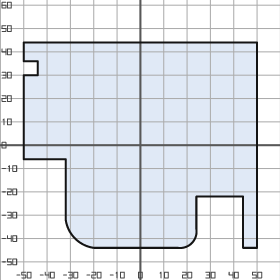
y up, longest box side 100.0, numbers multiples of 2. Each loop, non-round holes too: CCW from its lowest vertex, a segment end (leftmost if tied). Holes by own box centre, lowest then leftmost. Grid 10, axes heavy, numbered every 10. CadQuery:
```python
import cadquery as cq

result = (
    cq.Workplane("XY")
    .moveTo(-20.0, -44.0)
    .lineTo(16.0, -44.0)
    .threePointArc((22.0, -42.0), (24.0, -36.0))
    .lineTo(24.0, -22.0)
    .lineTo(44.0, -22.0)
    .lineTo(44.0, -44.0)
    .lineTo(50.0, -44.0)
    .lineTo(50.0, 44.0)
    .lineTo(-50.0, 44.0)
    .lineTo(-50.0, 36.0)
    .lineTo(-44.0, 36.0)
    .lineTo(-44.0, 30.0)
    .lineTo(-50.0, 30.0)
    .lineTo(-50.0, -6.0)
    .lineTo(-32.0, -6.0)
    .lineTo(-32.0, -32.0)
    .threePointArc((-28.0, -40.0), (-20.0, -44.0))
    .close()
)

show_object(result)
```